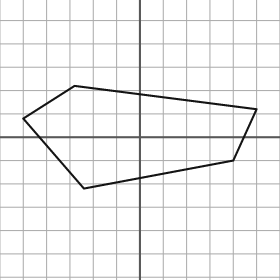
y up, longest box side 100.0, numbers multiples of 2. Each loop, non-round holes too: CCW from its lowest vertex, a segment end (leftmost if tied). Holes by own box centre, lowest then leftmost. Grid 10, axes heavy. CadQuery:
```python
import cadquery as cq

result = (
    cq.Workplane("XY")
    .moveTo(-24.0, -22.0)
    .lineTo(40.0, -10.0)
    .lineTo(50.0, 12.0)
    .lineTo(-28.0, 22.0)
    .lineTo(-50.0, 8.0)
    .close()
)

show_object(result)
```